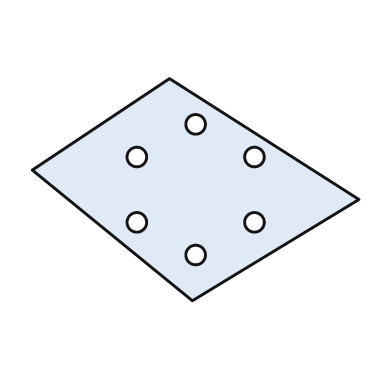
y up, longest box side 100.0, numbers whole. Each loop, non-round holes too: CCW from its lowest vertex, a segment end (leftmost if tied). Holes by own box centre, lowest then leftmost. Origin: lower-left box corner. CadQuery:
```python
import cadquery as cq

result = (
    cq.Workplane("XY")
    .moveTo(49.0, 0.0)
    .lineTo(100.0, 31.0)
    .lineTo(42.0, 68.0)
    .lineTo(0.0, 40.0)
    .close()
    .moveTo(50.0, 14.0)
    .circle(3.0)
    .moveTo(32.0, 24.0)
    .circle(3.0)
    .moveTo(68.0, 24.0)
    .circle(3.0)
    .moveTo(32.0, 44.0)
    .circle(3.0)
    .moveTo(68.0, 44.0)
    .circle(3.0)
    .moveTo(50.0, 54.0)
    .circle(3.0)
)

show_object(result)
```